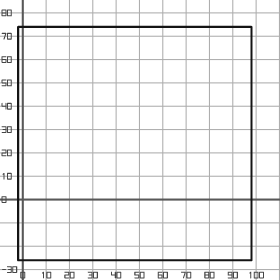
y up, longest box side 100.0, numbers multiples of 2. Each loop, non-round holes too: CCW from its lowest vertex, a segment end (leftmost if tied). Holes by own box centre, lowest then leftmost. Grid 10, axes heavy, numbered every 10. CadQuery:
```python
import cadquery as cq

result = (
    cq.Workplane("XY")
    .moveTo(-2.0, -26.0)
    .lineTo(98.0, -26.0)
    .lineTo(98.0, 74.0)
    .lineTo(-2.0, 74.0)
    .close()
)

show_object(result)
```